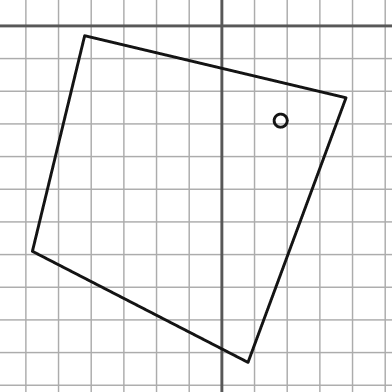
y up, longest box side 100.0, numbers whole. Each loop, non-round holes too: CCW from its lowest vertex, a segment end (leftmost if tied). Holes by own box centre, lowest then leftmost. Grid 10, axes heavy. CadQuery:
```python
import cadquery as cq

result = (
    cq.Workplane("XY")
    .moveTo(8.0, -103.0)
    .lineTo(38.0, -22.0)
    .lineTo(-42.0, -3.0)
    .lineTo(-58.0, -69.0)
    .close()
    .moveTo(18.0, -29.0)
    .circle(2.0)
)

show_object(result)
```